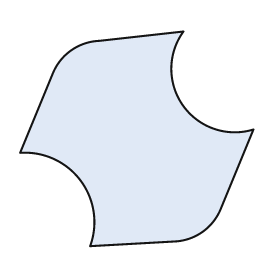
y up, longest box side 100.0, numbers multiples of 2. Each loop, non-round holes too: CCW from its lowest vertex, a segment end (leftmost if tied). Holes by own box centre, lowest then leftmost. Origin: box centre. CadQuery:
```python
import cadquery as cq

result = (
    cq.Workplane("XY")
    .moveTo(-20.0, -46.0)
    .lineTo(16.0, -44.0)
    .threePointArc((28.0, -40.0), (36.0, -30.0))
    .lineTo(50.0, 4.0)
    .threePointArc((20.0, 14.0), (20.0, 46.0))
    .lineTo(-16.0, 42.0)
    .threePointArc((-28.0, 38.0), (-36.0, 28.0))
    .lineTo(-50.0, -6.0)
    .threePointArc((-24.0, -18.0), (-20.0, -46.0))
    .close()
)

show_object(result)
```